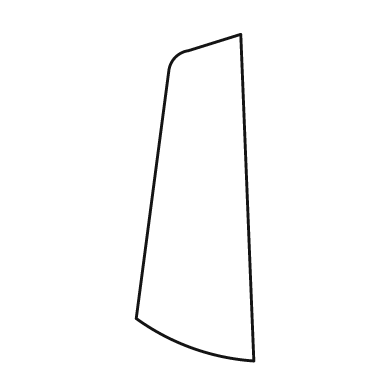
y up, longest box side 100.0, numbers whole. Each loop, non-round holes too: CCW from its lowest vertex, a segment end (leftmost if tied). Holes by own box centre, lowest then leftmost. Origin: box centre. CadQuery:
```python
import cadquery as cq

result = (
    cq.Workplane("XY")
    .moveTo(18.0, -50.0)
    .lineTo(14.0, 50.0)
    .lineTo(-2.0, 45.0)
    .threePointArc((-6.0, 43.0), (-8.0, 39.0))
    .lineTo(-18.0, -37.0)
    .threePointArc((-1.0, -46.0), (18.0, -50.0))
    .close()
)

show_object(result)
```